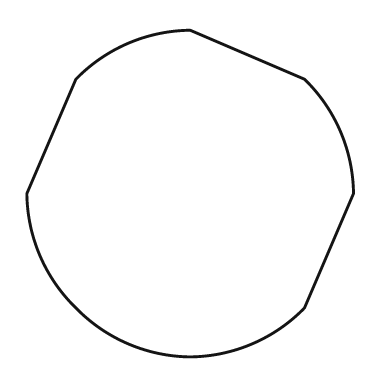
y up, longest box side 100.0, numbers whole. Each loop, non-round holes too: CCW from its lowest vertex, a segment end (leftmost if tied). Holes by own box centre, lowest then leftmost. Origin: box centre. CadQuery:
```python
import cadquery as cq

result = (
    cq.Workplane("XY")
    .moveTo(0.0, -50.0)
    .threePointArc((19.0, -46.0), (35.0, -35.0))
    .lineTo(50.0, 0.0)
    .threePointArc((46.0, 19.0), (35.0, 35.0))
    .lineTo(0.0, 50.0)
    .threePointArc((-19.0, 46.0), (-35.0, 35.0))
    .lineTo(-50.0, 0.0)
    .threePointArc((-46.0, -19.0), (-35.0, -35.0))
    .threePointArc((-19.0, -46.0), (0.0, -50.0))
    .close()
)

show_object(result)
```